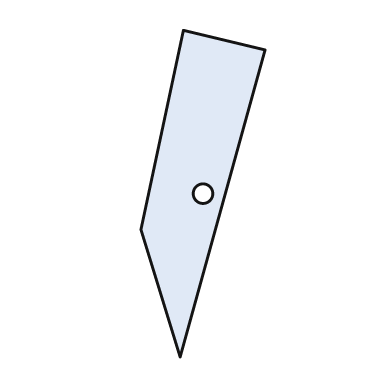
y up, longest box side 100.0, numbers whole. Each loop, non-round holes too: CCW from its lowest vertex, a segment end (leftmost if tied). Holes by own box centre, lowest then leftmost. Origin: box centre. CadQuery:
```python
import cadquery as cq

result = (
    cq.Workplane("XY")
    .moveTo(-7.0, -50.0)
    .lineTo(19.0, 44.0)
    .lineTo(-6.0, 50.0)
    .lineTo(-19.0, -11.0)
    .close()
    .moveTo(0.0, 0.0)
    .circle(3.0)
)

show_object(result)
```